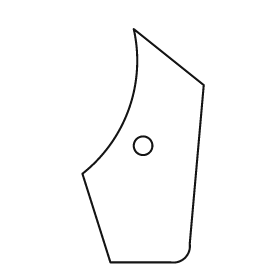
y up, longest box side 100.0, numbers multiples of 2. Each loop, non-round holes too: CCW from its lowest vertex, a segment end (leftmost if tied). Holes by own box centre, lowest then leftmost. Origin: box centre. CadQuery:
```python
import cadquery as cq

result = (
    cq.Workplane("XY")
    .moveTo(-14.0, -50.0)
    .lineTo(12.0, -50.0)
    .threePointArc((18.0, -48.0), (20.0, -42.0))
    .lineTo(26.0, 26.0)
    .lineTo(-4.0, 50.0)
    .threePointArc((-6.0, 16.0), (-26.0, -12.0))
    .close()
    .moveTo(0.0, 0.0)
    .circle(4.0)
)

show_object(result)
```